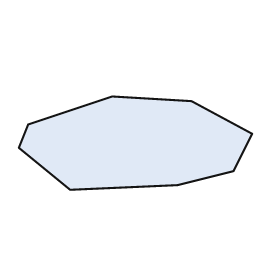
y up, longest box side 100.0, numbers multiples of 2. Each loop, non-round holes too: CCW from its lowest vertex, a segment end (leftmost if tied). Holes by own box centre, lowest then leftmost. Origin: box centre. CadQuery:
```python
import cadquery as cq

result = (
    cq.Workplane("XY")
    .moveTo(-28.0, -20.0)
    .lineTo(18.0, -18.0)
    .lineTo(42.0, -12.0)
    .lineTo(50.0, 4.0)
    .lineTo(24.0, 18.0)
    .lineTo(-10.0, 20.0)
    .lineTo(-46.0, 8.0)
    .lineTo(-50.0, -2.0)
    .close()
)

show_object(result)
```